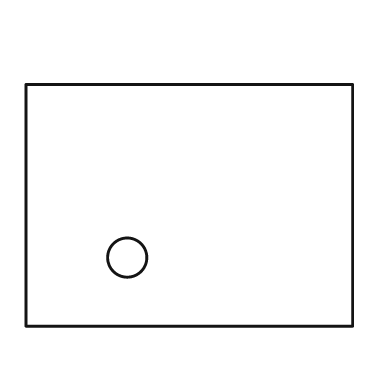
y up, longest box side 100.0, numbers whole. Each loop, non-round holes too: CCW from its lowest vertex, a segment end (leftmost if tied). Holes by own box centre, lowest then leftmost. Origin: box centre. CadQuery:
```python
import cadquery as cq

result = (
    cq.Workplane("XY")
    .moveTo(-50.0, -37.0)
    .lineTo(50.0, -37.0)
    .lineTo(50.0, 37.0)
    .lineTo(-50.0, 37.0)
    .close()
    .moveTo(-19.0, -16.0)
    .circle(6.0)
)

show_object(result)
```